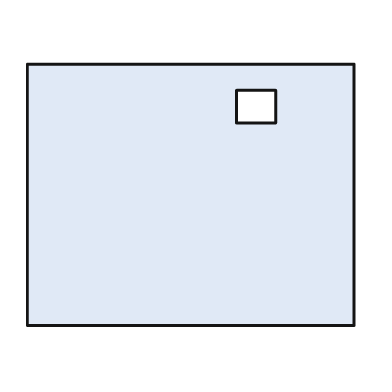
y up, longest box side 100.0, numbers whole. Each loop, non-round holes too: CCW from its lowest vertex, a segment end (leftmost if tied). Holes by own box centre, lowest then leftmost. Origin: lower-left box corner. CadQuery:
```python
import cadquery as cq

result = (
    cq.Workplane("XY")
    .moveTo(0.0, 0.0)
    .lineTo(100.0, 0.0)
    .lineTo(100.0, 80.0)
    .lineTo(0.0, 80.0)
    .close()
    .moveTo(64.0, 62.0)
    .lineTo(76.0, 62.0)
    .lineTo(76.0, 72.0)
    .lineTo(64.0, 72.0)
    .close()
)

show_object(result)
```